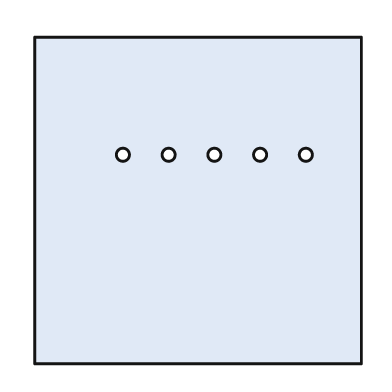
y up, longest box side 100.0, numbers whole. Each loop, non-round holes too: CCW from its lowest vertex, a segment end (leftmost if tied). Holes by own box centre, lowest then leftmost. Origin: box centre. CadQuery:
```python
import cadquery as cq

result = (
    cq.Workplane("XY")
    .moveTo(-50.0, -50.0)
    .lineTo(50.0, -50.0)
    .lineTo(50.0, 50.0)
    .lineTo(-50.0, 50.0)
    .close()
    .moveTo(-23.0, 14.0)
    .circle(2.0)
    .moveTo(-9.0, 14.0)
    .circle(2.0)
    .moveTo(5.0, 14.0)
    .circle(2.0)
    .moveTo(19.0, 14.0)
    .circle(2.0)
    .moveTo(33.0, 14.0)
    .circle(2.0)
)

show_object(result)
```